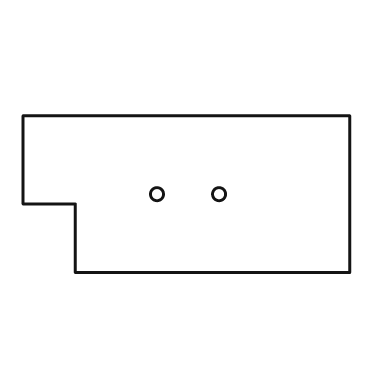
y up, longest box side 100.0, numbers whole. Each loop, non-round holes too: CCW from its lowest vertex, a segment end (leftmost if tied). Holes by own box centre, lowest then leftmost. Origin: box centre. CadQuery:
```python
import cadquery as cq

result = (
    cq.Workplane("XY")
    .moveTo(-34.0, -24.0)
    .lineTo(50.0, -24.0)
    .lineTo(50.0, 24.0)
    .lineTo(-50.0, 24.0)
    .lineTo(-50.0, -3.0)
    .lineTo(-34.0, -3.0)
    .close()
    .moveTo(-9.0, 0.0)
    .circle(2.0)
    .moveTo(10.0, 0.0)
    .circle(2.0)
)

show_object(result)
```